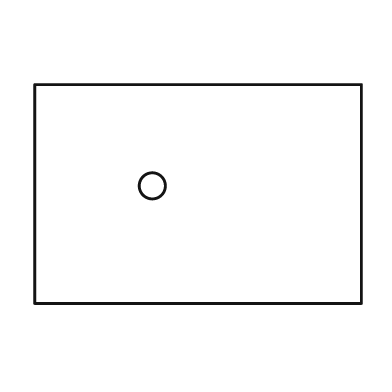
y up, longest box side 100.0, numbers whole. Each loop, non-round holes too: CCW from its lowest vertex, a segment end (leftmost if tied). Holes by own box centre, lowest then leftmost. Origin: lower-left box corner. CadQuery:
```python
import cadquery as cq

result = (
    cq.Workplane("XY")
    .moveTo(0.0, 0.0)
    .lineTo(100.0, 0.0)
    .lineTo(100.0, 67.0)
    .lineTo(0.0, 67.0)
    .close()
    .moveTo(36.0, 36.0)
    .circle(4.0)
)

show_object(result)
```